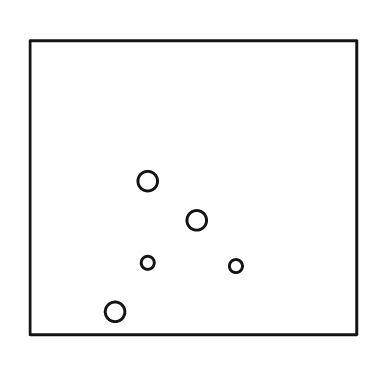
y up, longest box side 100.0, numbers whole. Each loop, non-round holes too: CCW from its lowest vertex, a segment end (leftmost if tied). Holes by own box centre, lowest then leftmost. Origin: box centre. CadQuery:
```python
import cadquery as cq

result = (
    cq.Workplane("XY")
    .moveTo(-50.0, -45.0)
    .lineTo(50.0, -45.0)
    .lineTo(50.0, 45.0)
    .lineTo(-50.0, 45.0)
    .close()
    .moveTo(-24.0, -38.0)
    .circle(3.0)
    .moveTo(13.0, -24.0)
    .circle(2.0)
    .moveTo(-14.0, -23.0)
    .circle(2.0)
    .moveTo(1.0, -10.0)
    .circle(3.0)
    .moveTo(-14.0, 2.0)
    .circle(3.0)
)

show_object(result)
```